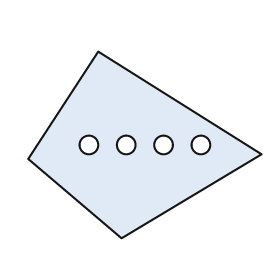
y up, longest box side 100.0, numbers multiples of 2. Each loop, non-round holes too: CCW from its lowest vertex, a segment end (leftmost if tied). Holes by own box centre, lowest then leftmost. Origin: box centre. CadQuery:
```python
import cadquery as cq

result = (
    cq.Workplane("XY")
    .moveTo(-10.0, -40.0)
    .lineTo(50.0, -4.0)
    .lineTo(-20.0, 40.0)
    .lineTo(-50.0, -6.0)
    .close()
    .moveTo(-24.0, 0.0)
    .circle(4.0)
    .moveTo(-8.0, 0.0)
    .circle(4.0)
    .moveTo(8.0, 0.0)
    .circle(4.0)
    .moveTo(24.0, 0.0)
    .circle(4.0)
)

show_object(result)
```